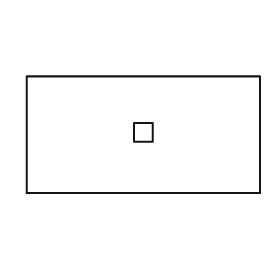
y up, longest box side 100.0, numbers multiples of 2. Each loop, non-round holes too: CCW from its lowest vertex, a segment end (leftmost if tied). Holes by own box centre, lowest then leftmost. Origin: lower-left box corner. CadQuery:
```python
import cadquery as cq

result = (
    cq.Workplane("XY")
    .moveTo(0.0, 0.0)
    .lineTo(100.0, 0.0)
    .lineTo(100.0, 50.0)
    .lineTo(0.0, 50.0)
    .close()
    .moveTo(46.0, 22.0)
    .lineTo(54.0, 22.0)
    .lineTo(54.0, 30.0)
    .lineTo(46.0, 30.0)
    .close()
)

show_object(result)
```